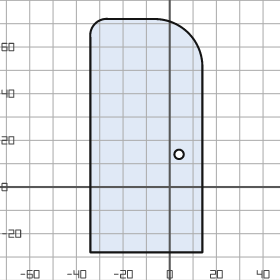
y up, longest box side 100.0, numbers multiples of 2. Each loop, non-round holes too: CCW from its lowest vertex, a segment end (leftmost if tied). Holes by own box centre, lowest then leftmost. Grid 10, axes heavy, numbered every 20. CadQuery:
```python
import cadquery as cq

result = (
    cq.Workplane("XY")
    .moveTo(-34.0, -28.0)
    .lineTo(14.0, -28.0)
    .lineTo(14.0, 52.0)
    .threePointArc((8.0, 66.0), (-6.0, 72.0))
    .lineTo(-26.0, 72.0)
    .threePointArc((-32.0, 70.0), (-34.0, 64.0))
    .close()
    .moveTo(4.0, 14.0)
    .circle(2.0)
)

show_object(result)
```